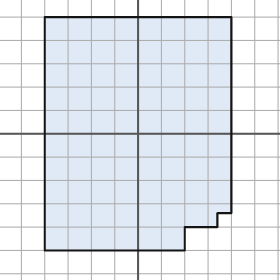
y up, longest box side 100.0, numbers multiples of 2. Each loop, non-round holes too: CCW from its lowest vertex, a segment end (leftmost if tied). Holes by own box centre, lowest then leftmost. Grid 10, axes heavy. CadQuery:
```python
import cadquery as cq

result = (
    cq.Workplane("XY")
    .moveTo(-40.0, -50.0)
    .lineTo(20.0, -50.0)
    .lineTo(20.0, -40.0)
    .lineTo(34.0, -40.0)
    .lineTo(34.0, -34.0)
    .lineTo(40.0, -34.0)
    .lineTo(40.0, 50.0)
    .lineTo(-40.0, 50.0)
    .close()
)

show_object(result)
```